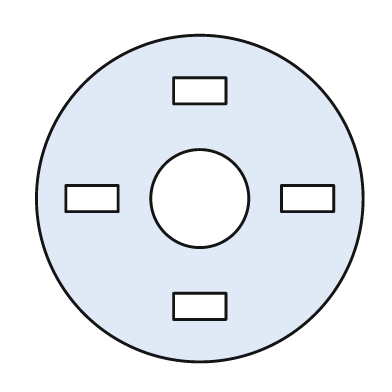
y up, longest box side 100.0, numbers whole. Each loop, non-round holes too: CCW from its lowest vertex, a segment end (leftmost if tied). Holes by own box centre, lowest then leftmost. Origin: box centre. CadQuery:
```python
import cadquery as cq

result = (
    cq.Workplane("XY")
    .moveTo(0.0, 0.0)
    .circle(50.0)
    .moveTo(-8.0, -37.0)
    .lineTo(8.0, -37.0)
    .lineTo(8.0, -29.0)
    .lineTo(-8.0, -29.0)
    .close()
    .moveTo(-41.0, -4.0)
    .lineTo(-25.0, -4.0)
    .lineTo(-25.0, 4.0)
    .lineTo(-41.0, 4.0)
    .close()
    .moveTo(0.0, 0.0)
    .circle(15.0)
    .moveTo(25.0, -4.0)
    .lineTo(41.0, -4.0)
    .lineTo(41.0, 4.0)
    .lineTo(25.0, 4.0)
    .close()
    .moveTo(-8.0, 29.0)
    .lineTo(8.0, 29.0)
    .lineTo(8.0, 37.0)
    .lineTo(-8.0, 37.0)
    .close()
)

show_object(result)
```